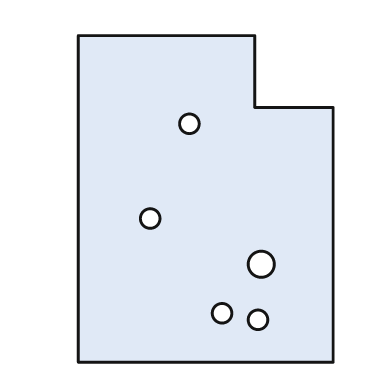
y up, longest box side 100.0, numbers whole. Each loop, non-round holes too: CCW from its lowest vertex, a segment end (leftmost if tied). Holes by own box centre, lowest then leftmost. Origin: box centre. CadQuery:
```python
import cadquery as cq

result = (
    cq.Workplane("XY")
    .moveTo(-39.0, -50.0)
    .lineTo(39.0, -50.0)
    .lineTo(39.0, 28.0)
    .lineTo(15.0, 28.0)
    .lineTo(15.0, 50.0)
    .lineTo(-39.0, 50.0)
    .close()
    .moveTo(16.0, -37.0)
    .circle(3.0)
    .moveTo(5.0, -35.0)
    .circle(3.0)
    .moveTo(17.0, -20.0)
    .circle(4.0)
    .moveTo(-17.0, -6.0)
    .circle(3.0)
    .moveTo(-5.0, 23.0)
    .circle(3.0)
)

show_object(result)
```